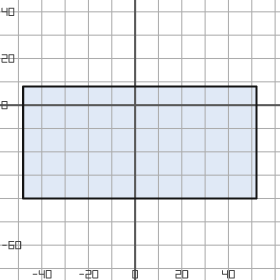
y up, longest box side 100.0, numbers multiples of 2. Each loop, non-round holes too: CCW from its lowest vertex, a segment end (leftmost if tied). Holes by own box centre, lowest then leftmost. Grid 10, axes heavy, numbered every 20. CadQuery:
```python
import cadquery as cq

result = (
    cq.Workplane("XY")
    .moveTo(-48.0, -40.0)
    .lineTo(52.0, -40.0)
    .lineTo(52.0, 8.0)
    .lineTo(-48.0, 8.0)
    .close()
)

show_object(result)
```